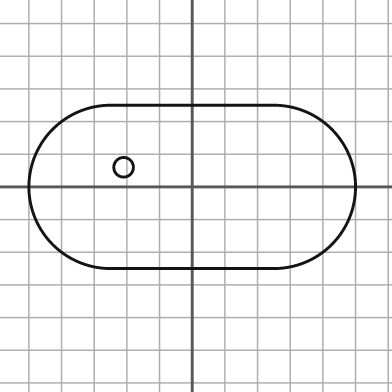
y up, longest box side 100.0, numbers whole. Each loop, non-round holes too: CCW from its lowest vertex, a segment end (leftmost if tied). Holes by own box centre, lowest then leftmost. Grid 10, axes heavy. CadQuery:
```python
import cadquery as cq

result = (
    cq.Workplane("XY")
    .moveTo(-25.0, -25.0)
    .lineTo(25.0, -25.0)
    .threePointArc((50.0, 0.0), (25.0, 25.0))
    .lineTo(-25.0, 25.0)
    .threePointArc((-50.0, 0.0), (-25.0, -25.0))
    .close()
    .moveTo(-21.0, 6.0)
    .circle(3.0)
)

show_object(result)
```